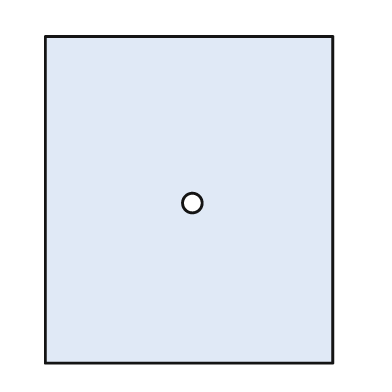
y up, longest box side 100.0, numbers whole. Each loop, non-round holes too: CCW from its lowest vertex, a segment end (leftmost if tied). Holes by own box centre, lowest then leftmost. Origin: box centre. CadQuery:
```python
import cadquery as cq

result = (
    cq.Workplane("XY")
    .moveTo(-44.0, -50.0)
    .lineTo(44.0, -50.0)
    .lineTo(44.0, 50.0)
    .lineTo(-44.0, 50.0)
    .close()
    .moveTo(1.0, -1.0)
    .circle(3.0)
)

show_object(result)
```